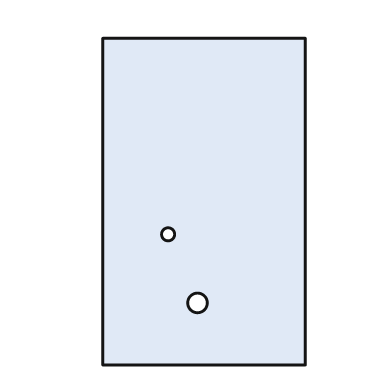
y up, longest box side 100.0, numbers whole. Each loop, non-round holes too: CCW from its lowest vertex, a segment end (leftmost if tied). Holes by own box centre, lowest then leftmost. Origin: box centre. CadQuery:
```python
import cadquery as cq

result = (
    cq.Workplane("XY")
    .moveTo(-31.0, -50.0)
    .lineTo(31.0, -50.0)
    .lineTo(31.0, 50.0)
    .lineTo(-31.0, 50.0)
    .close()
    .moveTo(-2.0, -31.0)
    .circle(3.0)
    .moveTo(-11.0, -10.0)
    .circle(2.0)
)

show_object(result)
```